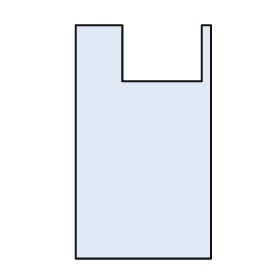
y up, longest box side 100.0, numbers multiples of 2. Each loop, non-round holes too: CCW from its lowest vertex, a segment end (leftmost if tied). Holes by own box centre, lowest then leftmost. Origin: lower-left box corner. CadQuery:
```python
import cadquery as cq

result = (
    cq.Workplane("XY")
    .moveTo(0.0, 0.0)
    .lineTo(58.0, 0.0)
    .lineTo(58.0, 100.0)
    .lineTo(54.0, 100.0)
    .lineTo(54.0, 76.0)
    .lineTo(20.0, 76.0)
    .lineTo(20.0, 100.0)
    .lineTo(0.0, 100.0)
    .close()
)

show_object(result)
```